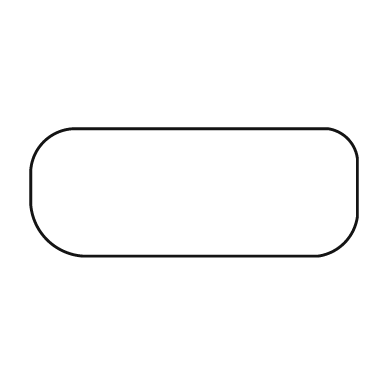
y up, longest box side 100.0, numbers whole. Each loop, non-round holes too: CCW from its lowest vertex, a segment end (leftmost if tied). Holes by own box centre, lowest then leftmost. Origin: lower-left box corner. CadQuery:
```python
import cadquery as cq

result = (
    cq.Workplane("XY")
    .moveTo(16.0, 0.0)
    .lineTo(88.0, 0.0)
    .threePointArc((96.0, 4.0), (100.0, 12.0))
    .lineTo(100.0, 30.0)
    .threePointArc((97.0, 36.0), (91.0, 39.0))
    .lineTo(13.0, 39.0)
    .threePointArc((4.0, 35.0), (0.0, 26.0))
    .lineTo(0.0, 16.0)
    .threePointArc((5.0, 5.0), (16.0, 0.0))
    .close()
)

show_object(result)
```